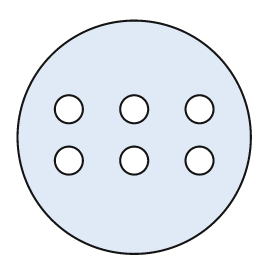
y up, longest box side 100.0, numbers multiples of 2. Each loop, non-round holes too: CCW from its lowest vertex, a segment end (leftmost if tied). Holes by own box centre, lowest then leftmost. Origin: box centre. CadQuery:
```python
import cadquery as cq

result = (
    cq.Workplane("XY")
    .moveTo(0.0, 0.0)
    .circle(50.0)
    .moveTo(-28.0, -10.0)
    .circle(6.0)
    .moveTo(0.0, -10.0)
    .circle(6.0)
    .moveTo(28.0, -10.0)
    .circle(6.0)
    .moveTo(-28.0, 12.0)
    .circle(6.0)
    .moveTo(0.0, 12.0)
    .circle(6.0)
    .moveTo(28.0, 12.0)
    .circle(6.0)
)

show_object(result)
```